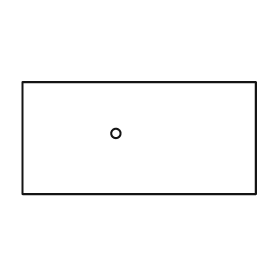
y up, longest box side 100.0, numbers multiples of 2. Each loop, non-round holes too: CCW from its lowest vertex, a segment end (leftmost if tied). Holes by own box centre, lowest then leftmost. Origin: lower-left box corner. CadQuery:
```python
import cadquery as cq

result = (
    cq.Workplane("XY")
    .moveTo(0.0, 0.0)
    .lineTo(100.0, 0.0)
    .lineTo(100.0, 48.0)
    .lineTo(0.0, 48.0)
    .close()
    .moveTo(40.0, 26.0)
    .circle(2.0)
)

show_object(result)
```